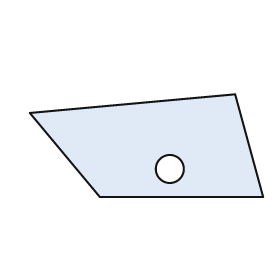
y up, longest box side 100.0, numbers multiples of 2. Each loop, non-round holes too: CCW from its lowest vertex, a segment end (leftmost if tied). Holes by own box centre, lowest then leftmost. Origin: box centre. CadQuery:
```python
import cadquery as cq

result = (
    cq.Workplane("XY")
    .moveTo(-20.0, -22.0)
    .lineTo(50.0, -22.0)
    .lineTo(38.0, 22.0)
    .lineTo(-50.0, 14.0)
    .close()
    .moveTo(10.0, -10.0)
    .circle(6.0)
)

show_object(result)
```